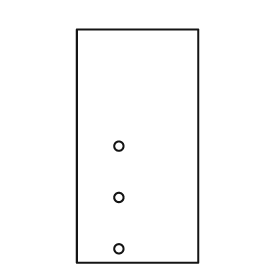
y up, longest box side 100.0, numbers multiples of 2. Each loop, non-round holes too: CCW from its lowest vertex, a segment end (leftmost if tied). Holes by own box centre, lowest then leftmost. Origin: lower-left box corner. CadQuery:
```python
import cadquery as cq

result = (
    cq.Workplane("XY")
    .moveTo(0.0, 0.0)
    .lineTo(52.0, 0.0)
    .lineTo(52.0, 100.0)
    .lineTo(0.0, 100.0)
    .close()
    .moveTo(18.0, 6.0)
    .circle(2.0)
    .moveTo(18.0, 28.0)
    .circle(2.0)
    .moveTo(18.0, 50.0)
    .circle(2.0)
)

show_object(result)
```